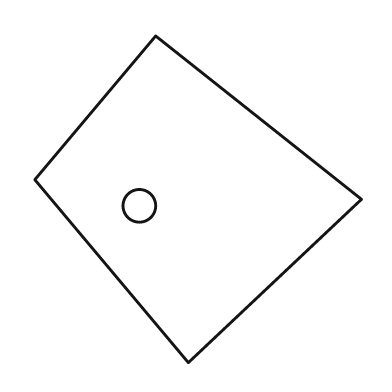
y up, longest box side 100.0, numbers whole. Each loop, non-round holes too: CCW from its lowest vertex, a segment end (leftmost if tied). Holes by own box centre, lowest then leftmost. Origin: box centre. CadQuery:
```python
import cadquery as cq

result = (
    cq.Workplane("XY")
    .moveTo(-3.0, -50.0)
    .lineTo(50.0, 0.0)
    .lineTo(-13.0, 50.0)
    .lineTo(-50.0, 6.0)
    .close()
    .moveTo(-18.0, -2.0)
    .circle(5.0)
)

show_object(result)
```